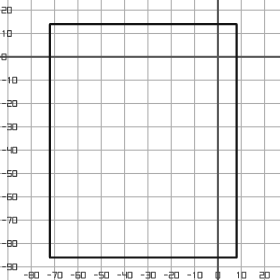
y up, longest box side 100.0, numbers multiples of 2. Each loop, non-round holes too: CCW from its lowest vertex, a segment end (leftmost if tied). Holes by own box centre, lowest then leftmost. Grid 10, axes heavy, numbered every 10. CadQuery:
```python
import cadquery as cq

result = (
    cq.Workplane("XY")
    .moveTo(-72.0, -86.0)
    .lineTo(8.0, -86.0)
    .lineTo(8.0, 14.0)
    .lineTo(-72.0, 14.0)
    .close()
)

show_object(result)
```